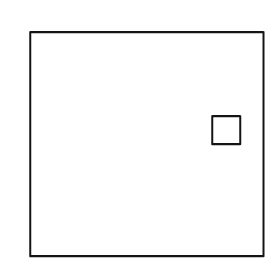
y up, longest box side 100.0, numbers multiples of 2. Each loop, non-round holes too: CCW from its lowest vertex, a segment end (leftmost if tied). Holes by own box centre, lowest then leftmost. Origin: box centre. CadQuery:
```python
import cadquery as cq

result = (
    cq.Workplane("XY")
    .moveTo(-50.0, -48.0)
    .lineTo(50.0, -48.0)
    .lineTo(50.0, 48.0)
    .lineTo(-50.0, 48.0)
    .close()
    .moveTo(28.0, 0.0)
    .lineTo(40.0, 0.0)
    .lineTo(40.0, 12.0)
    .lineTo(28.0, 12.0)
    .close()
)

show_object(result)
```